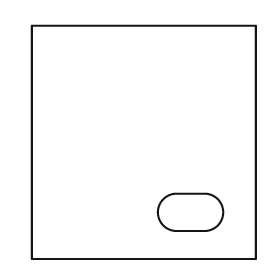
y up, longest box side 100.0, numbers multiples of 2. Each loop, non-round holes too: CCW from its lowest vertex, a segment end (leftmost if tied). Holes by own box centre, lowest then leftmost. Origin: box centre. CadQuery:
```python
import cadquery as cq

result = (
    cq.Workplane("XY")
    .moveTo(-48.0, -50.0)
    .lineTo(48.0, -50.0)
    .lineTo(48.0, 50.0)
    .lineTo(-48.0, 50.0)
    .close()
    .moveTo(14.0, -38.0)
    .lineTo(26.0, -38.0)
    .threePointArc((34.0, -30.0), (26.0, -22.0))
    .lineTo(14.0, -22.0)
    .threePointArc((6.0, -30.0), (14.0, -38.0))
    .close()
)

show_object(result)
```